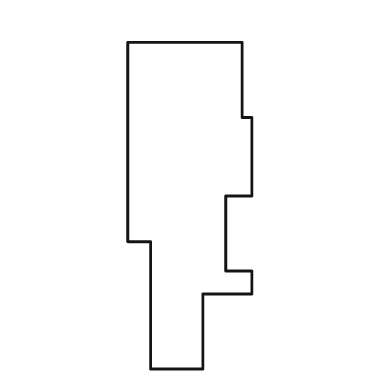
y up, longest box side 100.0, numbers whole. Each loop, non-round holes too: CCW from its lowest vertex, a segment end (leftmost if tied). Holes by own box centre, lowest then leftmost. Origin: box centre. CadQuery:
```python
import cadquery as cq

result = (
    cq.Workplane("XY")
    .moveTo(-12.0, -50.0)
    .lineTo(4.0, -50.0)
    .lineTo(4.0, -27.0)
    .lineTo(19.0, -27.0)
    .lineTo(19.0, -20.0)
    .lineTo(11.0, -20.0)
    .lineTo(11.0, 3.0)
    .lineTo(19.0, 3.0)
    .lineTo(19.0, 27.0)
    .lineTo(16.0, 27.0)
    .lineTo(16.0, 50.0)
    .lineTo(-19.0, 50.0)
    .lineTo(-19.0, -11.0)
    .lineTo(-12.0, -11.0)
    .close()
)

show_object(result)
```